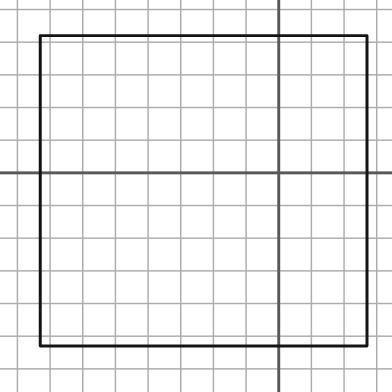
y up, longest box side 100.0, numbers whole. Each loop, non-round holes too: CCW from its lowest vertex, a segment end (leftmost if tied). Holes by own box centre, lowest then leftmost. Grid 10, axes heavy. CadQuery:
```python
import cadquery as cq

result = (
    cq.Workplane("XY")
    .moveTo(-73.0, -53.0)
    .lineTo(27.0, -53.0)
    .lineTo(27.0, 42.0)
    .lineTo(-73.0, 42.0)
    .close()
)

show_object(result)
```